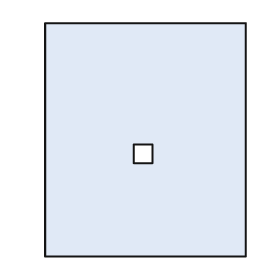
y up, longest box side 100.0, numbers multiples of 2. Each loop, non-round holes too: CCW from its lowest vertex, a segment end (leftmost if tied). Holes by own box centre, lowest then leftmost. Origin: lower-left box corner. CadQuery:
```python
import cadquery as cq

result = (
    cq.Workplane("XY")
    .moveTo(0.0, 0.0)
    .lineTo(86.0, 0.0)
    .lineTo(86.0, 100.0)
    .lineTo(0.0, 100.0)
    .close()
    .moveTo(38.0, 40.0)
    .lineTo(46.0, 40.0)
    .lineTo(46.0, 48.0)
    .lineTo(38.0, 48.0)
    .close()
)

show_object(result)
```